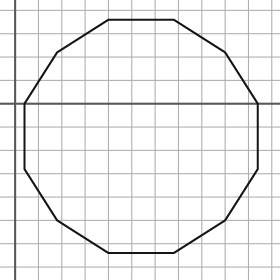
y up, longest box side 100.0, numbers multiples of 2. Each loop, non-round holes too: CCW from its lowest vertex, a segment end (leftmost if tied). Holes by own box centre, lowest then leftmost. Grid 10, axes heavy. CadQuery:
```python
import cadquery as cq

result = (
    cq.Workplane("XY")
    .moveTo(40.0, -64.0)
    .lineTo(68.0, -64.0)
    .lineTo(90.0, -50.0)
    .lineTo(104.0, -28.0)
    .lineTo(104.0, 0.0)
    .lineTo(90.0, 22.0)
    .lineTo(68.0, 36.0)
    .lineTo(40.0, 36.0)
    .lineTo(18.0, 22.0)
    .lineTo(4.0, 0.0)
    .lineTo(4.0, -28.0)
    .lineTo(18.0, -50.0)
    .close()
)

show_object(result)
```